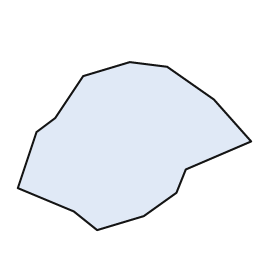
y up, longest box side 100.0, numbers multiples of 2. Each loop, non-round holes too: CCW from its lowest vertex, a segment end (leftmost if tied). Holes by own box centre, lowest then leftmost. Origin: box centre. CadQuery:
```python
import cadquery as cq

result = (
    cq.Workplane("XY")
    .moveTo(-16.0, -36.0)
    .lineTo(4.0, -30.0)
    .lineTo(18.0, -20.0)
    .lineTo(22.0, -10.0)
    .lineTo(50.0, 2.0)
    .lineTo(34.0, 20.0)
    .lineTo(14.0, 34.0)
    .lineTo(-2.0, 36.0)
    .lineTo(-22.0, 30.0)
    .lineTo(-34.0, 12.0)
    .lineTo(-42.0, 6.0)
    .lineTo(-50.0, -18.0)
    .lineTo(-26.0, -28.0)
    .close()
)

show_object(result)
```